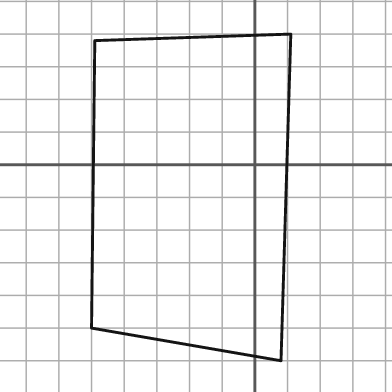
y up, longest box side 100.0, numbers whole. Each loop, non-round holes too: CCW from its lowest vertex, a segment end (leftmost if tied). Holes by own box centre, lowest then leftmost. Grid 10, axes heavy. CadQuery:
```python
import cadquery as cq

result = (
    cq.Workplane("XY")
    .moveTo(8.0, -60.0)
    .lineTo(11.0, 40.0)
    .lineTo(-49.0, 38.0)
    .lineTo(-50.0, -50.0)
    .close()
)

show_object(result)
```